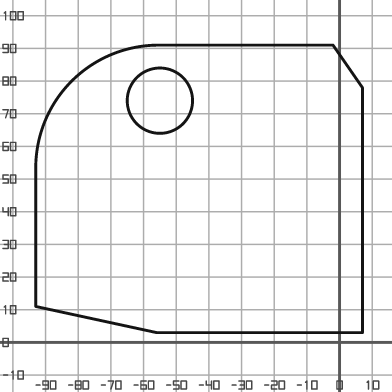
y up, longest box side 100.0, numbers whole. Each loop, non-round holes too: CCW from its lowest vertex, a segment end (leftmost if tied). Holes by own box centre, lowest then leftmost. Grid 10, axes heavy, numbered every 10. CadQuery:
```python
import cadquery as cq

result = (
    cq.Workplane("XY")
    .moveTo(-56.0, 3.0)
    .lineTo(7.0, 3.0)
    .lineTo(7.0, 78.0)
    .lineTo(-2.0, 91.0)
    .lineTo(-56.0, 91.0)
    .threePointArc((-82.0, 80.0), (-93.0, 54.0))
    .lineTo(-93.0, 11.0)
    .close()
    .moveTo(-55.0, 74.0)
    .circle(10.0)
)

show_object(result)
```